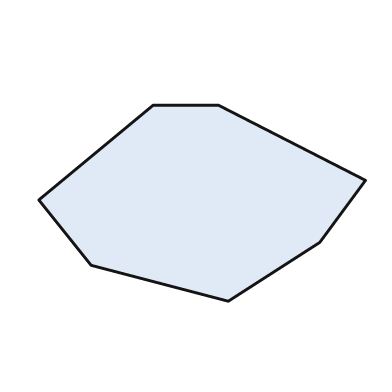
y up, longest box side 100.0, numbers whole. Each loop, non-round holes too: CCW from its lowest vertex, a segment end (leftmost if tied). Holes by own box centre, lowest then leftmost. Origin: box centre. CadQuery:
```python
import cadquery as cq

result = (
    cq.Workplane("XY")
    .moveTo(8.0, -30.0)
    .lineTo(36.0, -12.0)
    .lineTo(50.0, 7.0)
    .lineTo(5.0, 30.0)
    .lineTo(-15.0, 30.0)
    .lineTo(-50.0, 1.0)
    .lineTo(-34.0, -19.0)
    .close()
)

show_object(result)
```